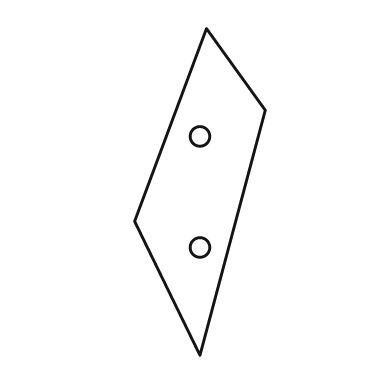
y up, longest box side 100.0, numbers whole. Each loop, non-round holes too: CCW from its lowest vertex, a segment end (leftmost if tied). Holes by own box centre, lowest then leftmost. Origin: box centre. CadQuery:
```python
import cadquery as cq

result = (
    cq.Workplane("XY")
    .moveTo(0.0, -50.0)
    .lineTo(20.0, 25.0)
    .lineTo(2.0, 50.0)
    .lineTo(-20.0, -9.0)
    .close()
    .moveTo(0.0, -17.0)
    .circle(3.0)
    .moveTo(0.0, 17.0)
    .circle(3.0)
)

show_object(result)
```